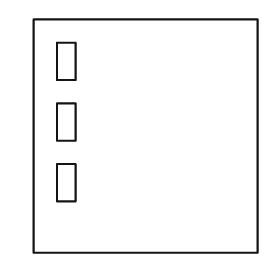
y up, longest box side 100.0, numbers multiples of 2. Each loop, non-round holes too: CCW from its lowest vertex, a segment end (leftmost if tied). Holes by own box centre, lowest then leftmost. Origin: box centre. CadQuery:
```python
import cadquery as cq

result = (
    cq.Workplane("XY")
    .moveTo(-48.0, -50.0)
    .lineTo(48.0, -50.0)
    .lineTo(48.0, 50.0)
    .lineTo(-48.0, 50.0)
    .close()
    .moveTo(-38.0, -28.0)
    .lineTo(-30.0, -28.0)
    .lineTo(-30.0, -12.0)
    .lineTo(-38.0, -12.0)
    .close()
    .moveTo(-38.0, -2.0)
    .lineTo(-30.0, -2.0)
    .lineTo(-30.0, 14.0)
    .lineTo(-38.0, 14.0)
    .close()
    .moveTo(-38.0, 24.0)
    .lineTo(-30.0, 24.0)
    .lineTo(-30.0, 40.0)
    .lineTo(-38.0, 40.0)
    .close()
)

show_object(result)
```